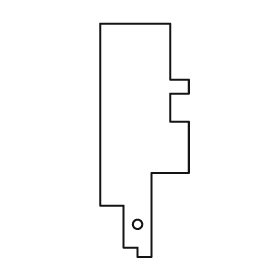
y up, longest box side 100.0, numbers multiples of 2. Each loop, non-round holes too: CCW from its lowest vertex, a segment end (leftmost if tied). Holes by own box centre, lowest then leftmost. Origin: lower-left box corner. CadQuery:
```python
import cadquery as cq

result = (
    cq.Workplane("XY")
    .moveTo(16.0, 0.0)
    .lineTo(22.0, 0.0)
    .lineTo(22.0, 36.0)
    .lineTo(38.0, 36.0)
    .lineTo(38.0, 58.0)
    .lineTo(30.0, 58.0)
    .lineTo(30.0, 70.0)
    .lineTo(38.0, 70.0)
    .lineTo(38.0, 76.0)
    .lineTo(30.0, 76.0)
    .lineTo(30.0, 100.0)
    .lineTo(0.0, 100.0)
    .lineTo(0.0, 22.0)
    .lineTo(10.0, 22.0)
    .lineTo(10.0, 4.0)
    .lineTo(16.0, 4.0)
    .close()
    .moveTo(16.0, 14.0)
    .circle(2.0)
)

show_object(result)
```